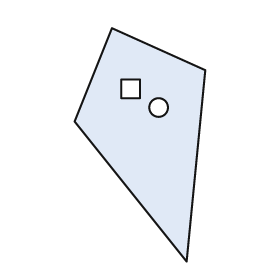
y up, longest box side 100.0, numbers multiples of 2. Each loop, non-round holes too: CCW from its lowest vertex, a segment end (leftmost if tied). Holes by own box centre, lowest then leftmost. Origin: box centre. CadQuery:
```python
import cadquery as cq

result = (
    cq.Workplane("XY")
    .moveTo(20.0, -50.0)
    .lineTo(28.0, 32.0)
    .lineTo(-12.0, 50.0)
    .lineTo(-28.0, 10.0)
    .close()
    .moveTo(8.0, 16.0)
    .circle(4.0)
    .moveTo(-8.0, 20.0)
    .lineTo(0.0, 20.0)
    .lineTo(0.0, 28.0)
    .lineTo(-8.0, 28.0)
    .close()
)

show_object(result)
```